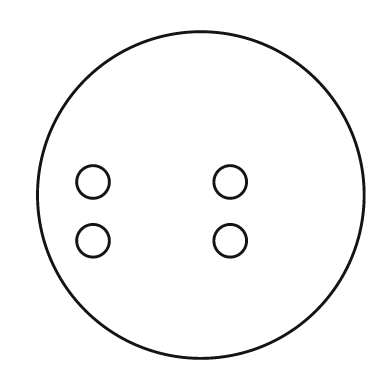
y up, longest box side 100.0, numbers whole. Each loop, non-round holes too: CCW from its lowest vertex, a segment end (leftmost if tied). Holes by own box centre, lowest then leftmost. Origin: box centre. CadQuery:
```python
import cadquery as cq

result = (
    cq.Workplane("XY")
    .moveTo(0.0, 0.0)
    .circle(50.0)
    .moveTo(-33.0, -14.0)
    .circle(5.0)
    .moveTo(9.0, -14.0)
    .circle(5.0)
    .moveTo(-33.0, 4.0)
    .circle(5.0)
    .moveTo(9.0, 4.0)
    .circle(5.0)
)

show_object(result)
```